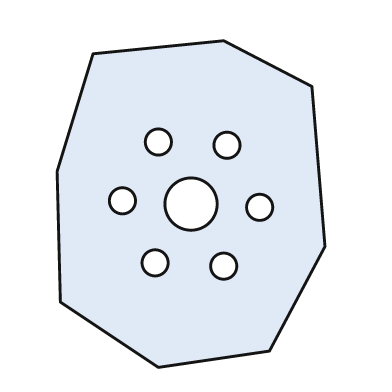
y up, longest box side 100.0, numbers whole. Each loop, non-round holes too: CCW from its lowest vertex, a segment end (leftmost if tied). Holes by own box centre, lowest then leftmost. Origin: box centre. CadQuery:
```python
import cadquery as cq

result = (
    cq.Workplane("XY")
    .moveTo(-10.0, -50.0)
    .lineTo(24.0, -45.0)
    .lineTo(41.0, -13.0)
    .lineTo(37.0, 36.0)
    .lineTo(10.0, 50.0)
    .lineTo(-30.0, 46.0)
    .lineTo(-41.0, 10.0)
    .lineTo(-40.0, -30.0)
    .close()
    .moveTo(10.0, -19.0)
    .circle(4.0)
    .moveTo(-11.0, -18.0)
    .circle(4.0)
    .moveTo(21.0, -1.0)
    .circle(4.0)
    .moveTo(0.0, 0.0)
    .circle(8.0)
    .moveTo(-21.0, 1.0)
    .circle(4.0)
    .moveTo(11.0, 18.0)
    .circle(4.0)
    .moveTo(-10.0, 19.0)
    .circle(4.0)
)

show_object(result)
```